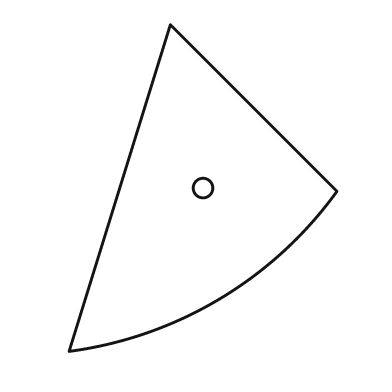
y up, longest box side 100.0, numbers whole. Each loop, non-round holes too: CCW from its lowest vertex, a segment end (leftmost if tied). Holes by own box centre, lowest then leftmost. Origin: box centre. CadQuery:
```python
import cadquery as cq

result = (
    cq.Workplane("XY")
    .moveTo(-41.0, -50.0)
    .threePointArc((5.0, -34.0), (41.0, -1.0))
    .lineTo(-10.0, 50.0)
    .close()
    .moveTo(0.0, 0.0)
    .circle(3.0)
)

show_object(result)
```